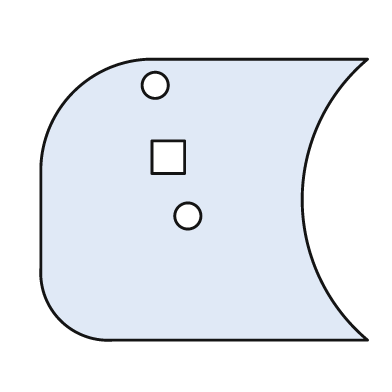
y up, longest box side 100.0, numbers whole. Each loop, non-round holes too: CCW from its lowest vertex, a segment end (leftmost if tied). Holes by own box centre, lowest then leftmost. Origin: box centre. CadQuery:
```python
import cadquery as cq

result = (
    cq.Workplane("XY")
    .moveTo(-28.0, -43.0)
    .lineTo(50.0, -43.0)
    .threePointArc((30.0, 0.0), (50.0, 43.0))
    .lineTo(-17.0, 43.0)
    .threePointArc((-40.0, 33.0), (-50.0, 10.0))
    .lineTo(-50.0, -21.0)
    .threePointArc((-44.0, -37.0), (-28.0, -43.0))
    .close()
    .moveTo(-5.0, -5.0)
    .circle(4.0)
    .moveTo(-16.0, 8.0)
    .lineTo(-6.0, 8.0)
    .lineTo(-6.0, 18.0)
    .lineTo(-16.0, 18.0)
    .close()
    .moveTo(-15.0, 35.0)
    .circle(4.0)
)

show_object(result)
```